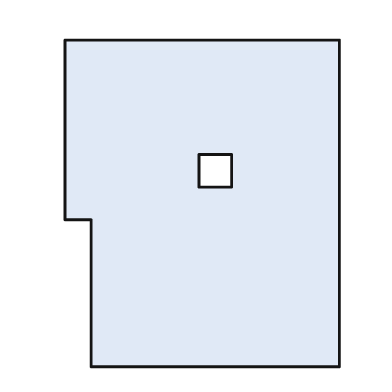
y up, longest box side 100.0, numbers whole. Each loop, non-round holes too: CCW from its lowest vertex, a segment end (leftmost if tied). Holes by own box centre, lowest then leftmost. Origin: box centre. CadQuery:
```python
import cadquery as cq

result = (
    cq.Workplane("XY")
    .moveTo(-34.0, -50.0)
    .lineTo(42.0, -50.0)
    .lineTo(42.0, 50.0)
    .lineTo(-42.0, 50.0)
    .lineTo(-42.0, -5.0)
    .lineTo(-34.0, -5.0)
    .close()
    .moveTo(-1.0, 5.0)
    .lineTo(9.0, 5.0)
    .lineTo(9.0, 15.0)
    .lineTo(-1.0, 15.0)
    .close()
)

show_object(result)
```